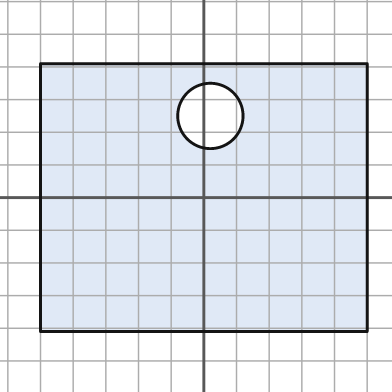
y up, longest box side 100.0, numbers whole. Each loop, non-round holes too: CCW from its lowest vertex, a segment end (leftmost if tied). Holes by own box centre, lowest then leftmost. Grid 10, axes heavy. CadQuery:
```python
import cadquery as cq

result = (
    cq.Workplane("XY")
    .moveTo(-50.0, -41.0)
    .lineTo(50.0, -41.0)
    .lineTo(50.0, 41.0)
    .lineTo(-50.0, 41.0)
    .close()
    .moveTo(2.0, 25.0)
    .circle(10.0)
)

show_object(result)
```